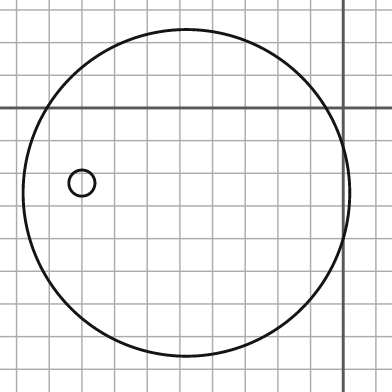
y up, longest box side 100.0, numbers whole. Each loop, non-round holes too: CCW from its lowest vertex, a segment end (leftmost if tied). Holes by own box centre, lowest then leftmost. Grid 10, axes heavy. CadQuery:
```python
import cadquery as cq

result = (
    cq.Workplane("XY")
    .moveTo(-48.0, -26.0)
    .circle(50.0)
    .moveTo(-80.0, -23.0)
    .circle(4.0)
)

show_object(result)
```